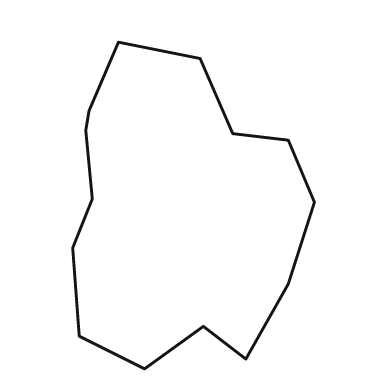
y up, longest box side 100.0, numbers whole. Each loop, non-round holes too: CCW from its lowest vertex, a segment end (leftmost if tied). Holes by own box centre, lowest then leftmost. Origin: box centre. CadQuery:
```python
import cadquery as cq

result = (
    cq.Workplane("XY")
    .moveTo(-15.0, -50.0)
    .lineTo(3.0, -37.0)
    .lineTo(16.0, -47.0)
    .lineTo(29.0, -24.0)
    .lineTo(37.0, 1.0)
    .lineTo(29.0, 20.0)
    .lineTo(12.0, 22.0)
    .lineTo(2.0, 45.0)
    .lineTo(-23.0, 50.0)
    .lineTo(-32.0, 29.0)
    .lineTo(-33.0, 23.0)
    .lineTo(-31.0, 2.0)
    .lineTo(-37.0, -13.0)
    .lineTo(-35.0, -40.0)
    .close()
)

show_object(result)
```